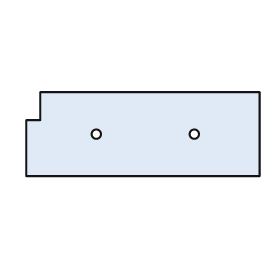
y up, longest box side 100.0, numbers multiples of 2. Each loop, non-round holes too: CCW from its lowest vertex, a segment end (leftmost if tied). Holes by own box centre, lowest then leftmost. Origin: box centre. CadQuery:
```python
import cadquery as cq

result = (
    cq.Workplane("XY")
    .moveTo(-50.0, -18.0)
    .lineTo(50.0, -18.0)
    .lineTo(50.0, 18.0)
    .lineTo(-44.0, 18.0)
    .lineTo(-44.0, 6.0)
    .lineTo(-50.0, 6.0)
    .close()
    .moveTo(-20.0, 0.0)
    .circle(2.0)
    .moveTo(22.0, 0.0)
    .circle(2.0)
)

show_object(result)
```